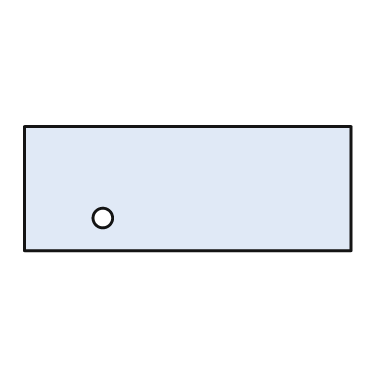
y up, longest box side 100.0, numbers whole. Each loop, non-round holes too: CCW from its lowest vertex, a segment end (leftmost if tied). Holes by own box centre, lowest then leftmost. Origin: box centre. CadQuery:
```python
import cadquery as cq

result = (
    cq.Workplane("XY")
    .moveTo(-50.0, -19.0)
    .lineTo(50.0, -19.0)
    .lineTo(50.0, 19.0)
    .lineTo(-50.0, 19.0)
    .close()
    .moveTo(-26.0, -9.0)
    .circle(3.0)
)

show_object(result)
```